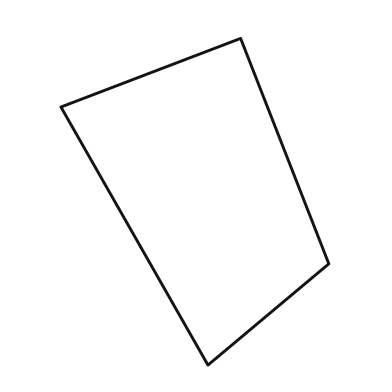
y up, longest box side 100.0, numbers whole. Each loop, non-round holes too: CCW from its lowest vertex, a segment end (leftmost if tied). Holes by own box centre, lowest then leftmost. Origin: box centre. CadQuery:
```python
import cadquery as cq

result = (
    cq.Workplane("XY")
    .moveTo(4.0, -50.0)
    .lineTo(41.0, -19.0)
    .lineTo(14.0, 50.0)
    .lineTo(-41.0, 29.0)
    .close()
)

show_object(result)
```